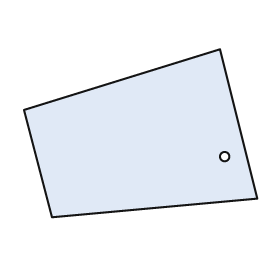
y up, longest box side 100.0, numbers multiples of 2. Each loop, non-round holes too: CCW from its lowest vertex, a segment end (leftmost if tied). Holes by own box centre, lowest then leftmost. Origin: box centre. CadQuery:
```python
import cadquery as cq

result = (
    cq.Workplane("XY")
    .moveTo(-38.0, -36.0)
    .lineTo(50.0, -28.0)
    .lineTo(34.0, 36.0)
    .lineTo(-50.0, 10.0)
    .close()
    .moveTo(36.0, -10.0)
    .circle(2.0)
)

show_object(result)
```